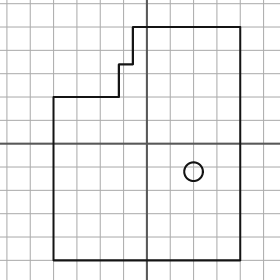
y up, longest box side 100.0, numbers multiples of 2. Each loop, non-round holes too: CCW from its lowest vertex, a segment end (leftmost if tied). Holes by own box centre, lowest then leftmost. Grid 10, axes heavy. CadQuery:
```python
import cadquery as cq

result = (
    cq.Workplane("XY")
    .moveTo(-40.0, -50.0)
    .lineTo(40.0, -50.0)
    .lineTo(40.0, 50.0)
    .lineTo(-6.0, 50.0)
    .lineTo(-6.0, 34.0)
    .lineTo(-12.0, 34.0)
    .lineTo(-12.0, 20.0)
    .lineTo(-40.0, 20.0)
    .close()
    .moveTo(20.0, -12.0)
    .circle(4.0)
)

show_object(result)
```